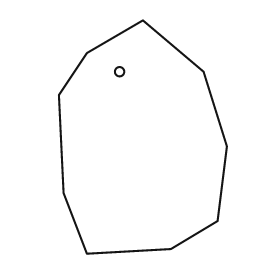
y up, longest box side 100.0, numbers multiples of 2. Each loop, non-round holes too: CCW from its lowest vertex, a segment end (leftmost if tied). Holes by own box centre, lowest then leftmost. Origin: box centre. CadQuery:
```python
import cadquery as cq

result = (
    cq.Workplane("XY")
    .moveTo(-24.0, -50.0)
    .lineTo(12.0, -48.0)
    .lineTo(32.0, -36.0)
    .lineTo(36.0, -4.0)
    .lineTo(26.0, 28.0)
    .lineTo(0.0, 50.0)
    .lineTo(-24.0, 36.0)
    .lineTo(-36.0, 18.0)
    .lineTo(-34.0, -24.0)
    .close()
    .moveTo(-10.0, 28.0)
    .circle(2.0)
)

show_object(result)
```